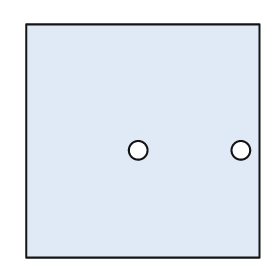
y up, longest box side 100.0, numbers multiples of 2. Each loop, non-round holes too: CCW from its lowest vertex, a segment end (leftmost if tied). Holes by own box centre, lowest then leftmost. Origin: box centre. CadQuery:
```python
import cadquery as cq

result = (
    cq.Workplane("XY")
    .moveTo(-50.0, -50.0)
    .lineTo(50.0, -50.0)
    .lineTo(50.0, 50.0)
    .lineTo(-50.0, 50.0)
    .close()
    .moveTo(-2.0, -4.0)
    .circle(4.0)
    .moveTo(42.0, -4.0)
    .circle(4.0)
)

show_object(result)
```